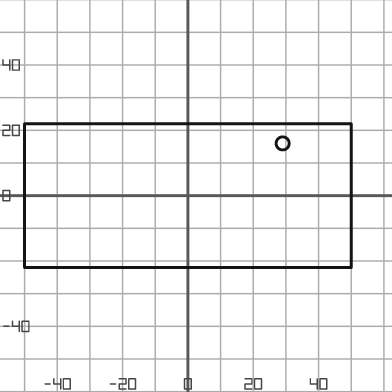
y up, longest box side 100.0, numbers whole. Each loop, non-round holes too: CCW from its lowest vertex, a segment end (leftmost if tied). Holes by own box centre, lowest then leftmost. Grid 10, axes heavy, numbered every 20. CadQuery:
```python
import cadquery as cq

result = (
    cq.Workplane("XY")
    .moveTo(-50.0, -22.0)
    .lineTo(50.0, -22.0)
    .lineTo(50.0, 22.0)
    .lineTo(-50.0, 22.0)
    .close()
    .moveTo(29.0, 16.0)
    .circle(2.0)
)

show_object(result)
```